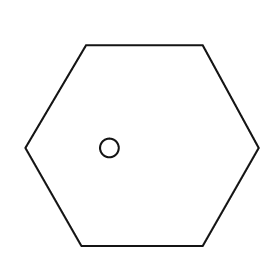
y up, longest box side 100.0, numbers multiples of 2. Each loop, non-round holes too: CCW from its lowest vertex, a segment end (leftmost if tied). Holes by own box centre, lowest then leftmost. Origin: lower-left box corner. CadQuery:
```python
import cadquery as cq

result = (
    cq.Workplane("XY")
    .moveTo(24.0, 0.0)
    .lineTo(76.0, 0.0)
    .lineTo(100.0, 42.0)
    .lineTo(76.0, 86.0)
    .lineTo(26.0, 86.0)
    .lineTo(0.0, 42.0)
    .close()
    .moveTo(36.0, 42.0)
    .circle(4.0)
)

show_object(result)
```